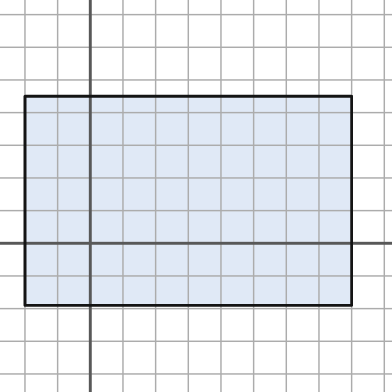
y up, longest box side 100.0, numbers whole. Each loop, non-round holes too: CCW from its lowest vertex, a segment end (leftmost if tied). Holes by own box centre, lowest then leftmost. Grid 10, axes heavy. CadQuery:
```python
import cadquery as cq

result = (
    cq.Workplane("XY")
    .moveTo(-20.0, -19.0)
    .lineTo(80.0, -19.0)
    .lineTo(80.0, 45.0)
    .lineTo(-20.0, 45.0)
    .close()
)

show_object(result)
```